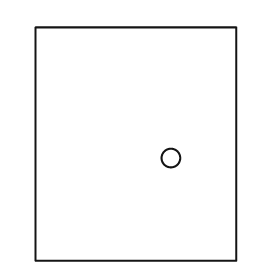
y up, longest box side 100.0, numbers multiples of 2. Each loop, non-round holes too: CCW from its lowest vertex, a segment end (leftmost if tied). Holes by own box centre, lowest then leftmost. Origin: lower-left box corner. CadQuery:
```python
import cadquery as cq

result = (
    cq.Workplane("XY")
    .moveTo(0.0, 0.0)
    .lineTo(86.0, 0.0)
    .lineTo(86.0, 100.0)
    .lineTo(0.0, 100.0)
    .close()
    .moveTo(58.0, 44.0)
    .circle(4.0)
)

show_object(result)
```